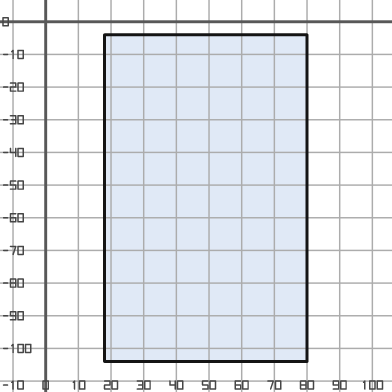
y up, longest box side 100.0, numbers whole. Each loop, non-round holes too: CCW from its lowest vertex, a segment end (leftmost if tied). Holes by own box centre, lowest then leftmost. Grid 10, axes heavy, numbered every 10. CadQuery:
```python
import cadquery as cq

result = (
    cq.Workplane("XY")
    .moveTo(18.0, -104.0)
    .lineTo(80.0, -104.0)
    .lineTo(80.0, -4.0)
    .lineTo(18.0, -4.0)
    .close()
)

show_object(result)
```